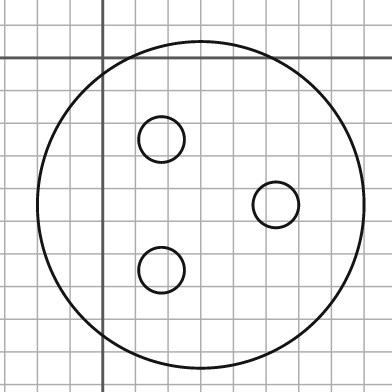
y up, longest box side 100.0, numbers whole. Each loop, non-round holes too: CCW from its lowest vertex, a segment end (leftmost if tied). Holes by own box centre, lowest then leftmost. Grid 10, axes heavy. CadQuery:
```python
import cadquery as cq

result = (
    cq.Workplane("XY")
    .moveTo(30.0, -45.0)
    .circle(50.0)
    .moveTo(18.0, -65.0)
    .circle(7.0)
    .moveTo(53.0, -45.0)
    .circle(7.0)
    .moveTo(18.0, -25.0)
    .circle(7.0)
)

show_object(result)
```